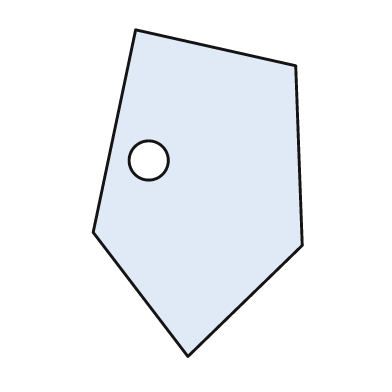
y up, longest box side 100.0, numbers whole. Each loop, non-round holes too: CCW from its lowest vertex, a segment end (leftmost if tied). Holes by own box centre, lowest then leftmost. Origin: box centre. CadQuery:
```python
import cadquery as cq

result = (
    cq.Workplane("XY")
    .moveTo(-3.0, -50.0)
    .lineTo(32.0, -16.0)
    .lineTo(30.0, 39.0)
    .lineTo(-19.0, 50.0)
    .lineTo(-32.0, -12.0)
    .close()
    .moveTo(-15.0, 10.0)
    .circle(6.0)
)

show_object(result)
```